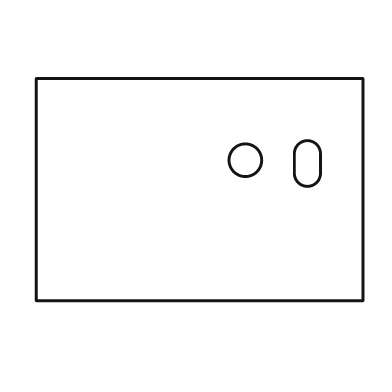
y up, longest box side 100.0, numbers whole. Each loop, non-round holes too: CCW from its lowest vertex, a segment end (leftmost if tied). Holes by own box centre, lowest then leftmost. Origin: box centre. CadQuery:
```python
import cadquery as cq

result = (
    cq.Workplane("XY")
    .moveTo(-50.0, -34.0)
    .lineTo(50.0, -34.0)
    .lineTo(50.0, 34.0)
    .lineTo(-50.0, 34.0)
    .close()
    .moveTo(29.0, 5.0)
    .threePointArc((33.0, 1.0), (37.0, 5.0))
    .lineTo(37.0, 11.0)
    .threePointArc((33.0, 15.0), (29.0, 11.0))
    .close()
    .moveTo(14.0, 9.0)
    .circle(5.0)
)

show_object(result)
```